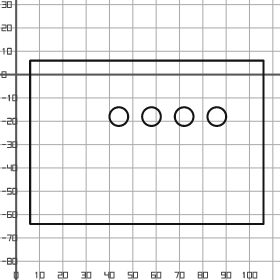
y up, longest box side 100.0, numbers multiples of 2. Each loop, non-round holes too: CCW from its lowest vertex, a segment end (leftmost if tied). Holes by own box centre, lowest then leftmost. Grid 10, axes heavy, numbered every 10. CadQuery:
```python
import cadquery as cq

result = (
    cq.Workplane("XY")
    .moveTo(6.0, -64.0)
    .lineTo(106.0, -64.0)
    .lineTo(106.0, 6.0)
    .lineTo(6.0, 6.0)
    .close()
    .moveTo(44.0, -18.0)
    .circle(4.0)
    .moveTo(58.0, -18.0)
    .circle(4.0)
    .moveTo(72.0, -18.0)
    .circle(4.0)
    .moveTo(86.0, -18.0)
    .circle(4.0)
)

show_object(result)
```